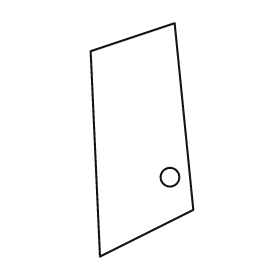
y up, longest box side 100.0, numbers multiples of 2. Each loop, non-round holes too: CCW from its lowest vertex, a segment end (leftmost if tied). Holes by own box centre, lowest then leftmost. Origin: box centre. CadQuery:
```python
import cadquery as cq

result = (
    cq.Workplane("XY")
    .moveTo(-18.0, -50.0)
    .lineTo(22.0, -30.0)
    .lineTo(14.0, 50.0)
    .lineTo(-22.0, 38.0)
    .close()
    .moveTo(12.0, -16.0)
    .circle(4.0)
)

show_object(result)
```